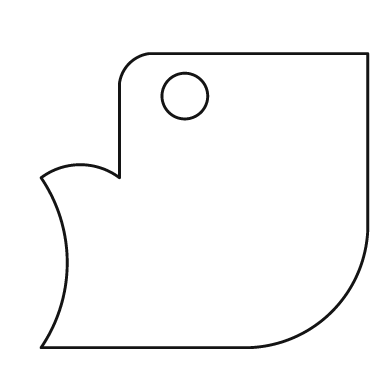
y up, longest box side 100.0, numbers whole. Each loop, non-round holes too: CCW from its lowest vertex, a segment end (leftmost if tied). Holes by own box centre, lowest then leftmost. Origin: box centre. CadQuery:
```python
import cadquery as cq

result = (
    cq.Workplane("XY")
    .moveTo(-50.0, -45.0)
    .lineTo(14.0, -45.0)
    .threePointArc((39.0, -34.0), (50.0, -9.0))
    .lineTo(50.0, 45.0)
    .lineTo(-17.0, 45.0)
    .threePointArc((-23.0, 42.0), (-26.0, 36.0))
    .lineTo(-26.0, 7.0)
    .threePointArc((-38.0, 11.0), (-50.0, 7.0))
    .threePointArc((-42.0, -19.0), (-50.0, -45.0))
    .close()
    .moveTo(-6.0, 32.0)
    .circle(7.0)
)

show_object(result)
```